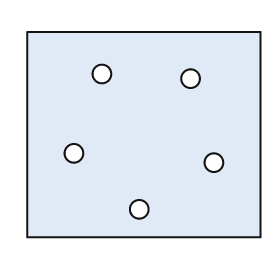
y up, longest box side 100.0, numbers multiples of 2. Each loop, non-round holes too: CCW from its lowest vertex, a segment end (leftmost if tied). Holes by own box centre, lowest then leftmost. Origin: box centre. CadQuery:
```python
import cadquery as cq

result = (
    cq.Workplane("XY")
    .moveTo(-50.0, -44.0)
    .lineTo(50.0, -44.0)
    .lineTo(50.0, 44.0)
    .lineTo(-50.0, 44.0)
    .close()
    .moveTo(-2.0, -32.0)
    .circle(4.0)
    .moveTo(30.0, -12.0)
    .circle(4.0)
    .moveTo(-30.0, -8.0)
    .circle(4.0)
    .moveTo(20.0, 24.0)
    .circle(4.0)
    .moveTo(-18.0, 26.0)
    .circle(4.0)
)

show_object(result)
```